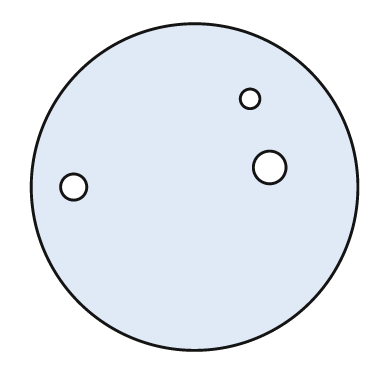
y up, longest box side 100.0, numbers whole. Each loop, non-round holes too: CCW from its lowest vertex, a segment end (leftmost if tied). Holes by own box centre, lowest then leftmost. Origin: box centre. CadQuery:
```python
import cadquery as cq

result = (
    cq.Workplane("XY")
    .moveTo(0.0, 0.0)
    .circle(50.0)
    .moveTo(-37.0, 0.0)
    .circle(4.0)
    .moveTo(23.0, 6.0)
    .circle(5.0)
    .moveTo(17.0, 27.0)
    .circle(3.0)
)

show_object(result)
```